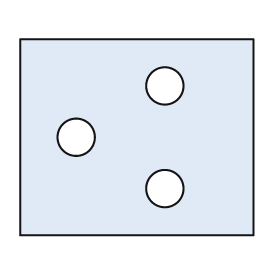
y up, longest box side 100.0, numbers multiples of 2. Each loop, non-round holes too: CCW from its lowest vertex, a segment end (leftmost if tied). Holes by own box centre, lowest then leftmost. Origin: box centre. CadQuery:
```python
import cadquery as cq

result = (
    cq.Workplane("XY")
    .moveTo(-50.0, -42.0)
    .lineTo(50.0, -42.0)
    .lineTo(50.0, 42.0)
    .lineTo(-50.0, 42.0)
    .close()
    .moveTo(12.0, -22.0)
    .circle(8.0)
    .moveTo(-26.0, 0.0)
    .circle(8.0)
    .moveTo(12.0, 22.0)
    .circle(8.0)
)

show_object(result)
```